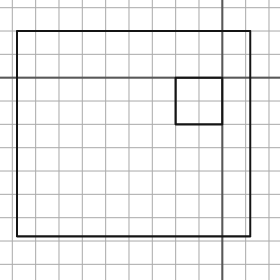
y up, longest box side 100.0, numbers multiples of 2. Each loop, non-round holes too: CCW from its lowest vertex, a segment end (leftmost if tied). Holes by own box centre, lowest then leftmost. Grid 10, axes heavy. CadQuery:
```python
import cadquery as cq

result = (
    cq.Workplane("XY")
    .moveTo(-88.0, -68.0)
    .lineTo(12.0, -68.0)
    .lineTo(12.0, 20.0)
    .lineTo(-88.0, 20.0)
    .close()
    .moveTo(-20.0, -20.0)
    .lineTo(0.0, -20.0)
    .lineTo(0.0, 0.0)
    .lineTo(-20.0, 0.0)
    .close()
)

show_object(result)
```